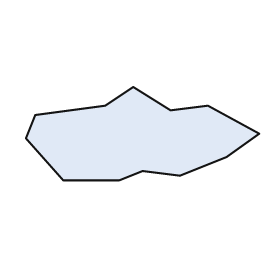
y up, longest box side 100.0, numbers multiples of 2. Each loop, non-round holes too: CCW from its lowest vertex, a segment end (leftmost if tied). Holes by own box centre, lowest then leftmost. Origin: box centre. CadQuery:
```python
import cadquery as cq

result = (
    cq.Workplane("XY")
    .moveTo(-34.0, -20.0)
    .lineTo(-10.0, -20.0)
    .lineTo(0.0, -16.0)
    .lineTo(16.0, -18.0)
    .lineTo(36.0, -10.0)
    .lineTo(50.0, 0.0)
    .lineTo(28.0, 12.0)
    .lineTo(12.0, 10.0)
    .lineTo(-4.0, 20.0)
    .lineTo(-16.0, 12.0)
    .lineTo(-46.0, 8.0)
    .lineTo(-50.0, -2.0)
    .close()
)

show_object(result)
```